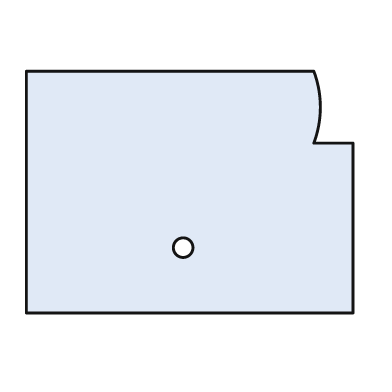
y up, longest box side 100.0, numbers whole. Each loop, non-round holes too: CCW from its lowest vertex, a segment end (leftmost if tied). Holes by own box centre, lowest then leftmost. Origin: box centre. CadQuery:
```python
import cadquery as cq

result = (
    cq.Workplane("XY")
    .moveTo(-50.0, -37.0)
    .lineTo(50.0, -37.0)
    .lineTo(50.0, 15.0)
    .lineTo(38.0, 15.0)
    .threePointArc((40.0, 26.0), (38.0, 37.0))
    .lineTo(-50.0, 37.0)
    .close()
    .moveTo(-2.0, -17.0)
    .circle(3.0)
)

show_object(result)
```